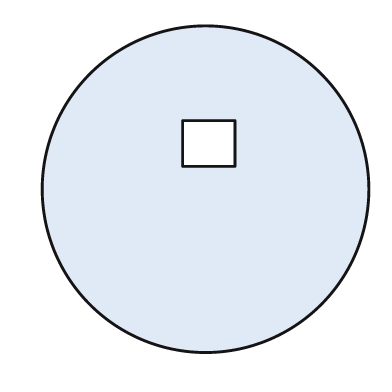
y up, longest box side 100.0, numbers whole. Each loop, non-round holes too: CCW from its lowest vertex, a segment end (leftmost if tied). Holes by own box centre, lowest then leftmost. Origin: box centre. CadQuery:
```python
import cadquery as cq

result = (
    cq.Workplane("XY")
    .moveTo(0.0, 0.0)
    .circle(50.0)
    .moveTo(-7.0, 7.0)
    .lineTo(9.0, 7.0)
    .lineTo(9.0, 21.0)
    .lineTo(-7.0, 21.0)
    .close()
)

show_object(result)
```